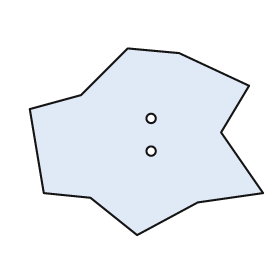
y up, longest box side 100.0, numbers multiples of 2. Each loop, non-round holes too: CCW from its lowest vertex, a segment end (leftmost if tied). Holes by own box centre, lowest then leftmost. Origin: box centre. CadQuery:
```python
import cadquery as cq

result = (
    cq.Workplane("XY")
    .moveTo(-4.0, -40.0)
    .lineTo(22.0, -26.0)
    .lineTo(50.0, -22.0)
    .lineTo(32.0, 4.0)
    .lineTo(44.0, 24.0)
    .lineTo(14.0, 38.0)
    .lineTo(-8.0, 40.0)
    .lineTo(-28.0, 20.0)
    .lineTo(-50.0, 14.0)
    .lineTo(-44.0, -22.0)
    .lineTo(-24.0, -24.0)
    .close()
    .moveTo(2.0, -4.0)
    .circle(2.0)
    .moveTo(2.0, 10.0)
    .circle(2.0)
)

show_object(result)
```